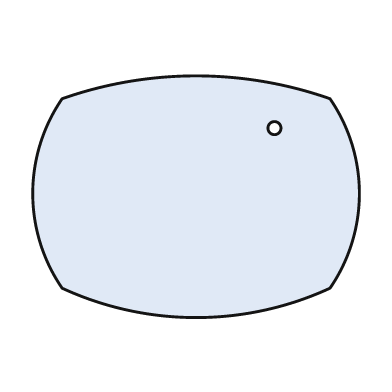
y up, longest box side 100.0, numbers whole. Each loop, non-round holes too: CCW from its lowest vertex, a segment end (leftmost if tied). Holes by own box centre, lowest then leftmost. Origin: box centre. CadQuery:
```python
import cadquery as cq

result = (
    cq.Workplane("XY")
    .moveTo(-41.0, -28.0)
    .threePointArc((0.0, -37.0), (41.0, -28.0))
    .threePointArc((50.0, 1.0), (41.0, 30.0))
    .threePointArc((0.0, 37.0), (-41.0, 30.0))
    .threePointArc((-50.0, 1.0), (-41.0, -28.0))
    .close()
    .moveTo(24.0, 21.0)
    .circle(2.0)
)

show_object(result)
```